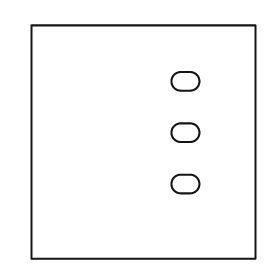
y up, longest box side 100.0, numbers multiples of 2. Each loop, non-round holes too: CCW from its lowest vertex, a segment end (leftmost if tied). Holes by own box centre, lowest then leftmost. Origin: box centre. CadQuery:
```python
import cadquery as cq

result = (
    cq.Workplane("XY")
    .moveTo(-48.0, -50.0)
    .lineTo(48.0, -50.0)
    .lineTo(48.0, 50.0)
    .lineTo(-48.0, 50.0)
    .close()
    .moveTo(16.0, -22.0)
    .lineTo(20.0, -22.0)
    .threePointArc((24.0, -18.0), (20.0, -14.0))
    .lineTo(16.0, -14.0)
    .threePointArc((12.0, -18.0), (16.0, -22.0))
    .close()
    .moveTo(16.0, 0.0)
    .lineTo(20.0, 0.0)
    .threePointArc((24.0, 4.0), (20.0, 8.0))
    .lineTo(16.0, 8.0)
    .threePointArc((12.0, 4.0), (16.0, 0.0))
    .close()
    .moveTo(16.0, 22.0)
    .lineTo(20.0, 22.0)
    .threePointArc((24.0, 26.0), (20.0, 30.0))
    .lineTo(16.0, 30.0)
    .threePointArc((12.0, 26.0), (16.0, 22.0))
    .close()
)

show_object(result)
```